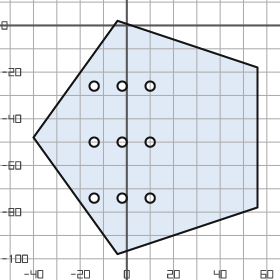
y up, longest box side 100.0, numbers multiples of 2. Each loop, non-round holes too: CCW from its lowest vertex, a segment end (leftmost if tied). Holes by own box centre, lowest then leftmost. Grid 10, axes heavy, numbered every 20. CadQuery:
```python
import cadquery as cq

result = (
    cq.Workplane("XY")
    .moveTo(-4.0, -98.0)
    .lineTo(56.0, -78.0)
    .lineTo(56.0, -18.0)
    .lineTo(-4.0, 2.0)
    .lineTo(-40.0, -48.0)
    .close()
    .moveTo(-14.0, -74.0)
    .circle(2.0)
    .moveTo(-2.0, -74.0)
    .circle(2.0)
    .moveTo(10.0, -74.0)
    .circle(2.0)
    .moveTo(-14.0, -50.0)
    .circle(2.0)
    .moveTo(-2.0, -50.0)
    .circle(2.0)
    .moveTo(10.0, -50.0)
    .circle(2.0)
    .moveTo(-14.0, -26.0)
    .circle(2.0)
    .moveTo(-2.0, -26.0)
    .circle(2.0)
    .moveTo(10.0, -26.0)
    .circle(2.0)
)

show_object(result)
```